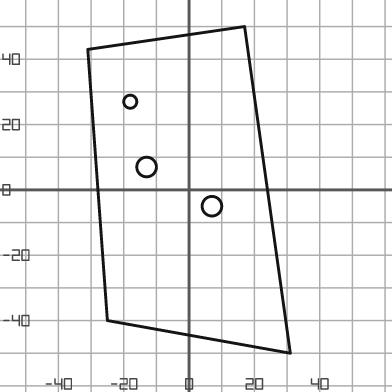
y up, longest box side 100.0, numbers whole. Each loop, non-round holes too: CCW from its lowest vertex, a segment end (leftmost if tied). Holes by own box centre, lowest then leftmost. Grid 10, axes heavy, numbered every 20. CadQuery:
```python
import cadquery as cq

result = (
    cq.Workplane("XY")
    .moveTo(31.0, -50.0)
    .lineTo(17.0, 50.0)
    .lineTo(-31.0, 43.0)
    .lineTo(-25.0, -40.0)
    .close()
    .moveTo(7.0, -5.0)
    .circle(3.0)
    .moveTo(-13.0, 7.0)
    .circle(3.0)
    .moveTo(-18.0, 27.0)
    .circle(2.0)
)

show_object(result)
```